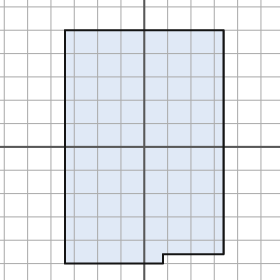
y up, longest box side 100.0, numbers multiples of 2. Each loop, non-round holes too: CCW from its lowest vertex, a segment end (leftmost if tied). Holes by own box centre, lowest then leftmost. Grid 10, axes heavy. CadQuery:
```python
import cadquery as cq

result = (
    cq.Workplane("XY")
    .moveTo(-34.0, -50.0)
    .lineTo(8.0, -50.0)
    .lineTo(8.0, -46.0)
    .lineTo(34.0, -46.0)
    .lineTo(34.0, 50.0)
    .lineTo(-34.0, 50.0)
    .close()
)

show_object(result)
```